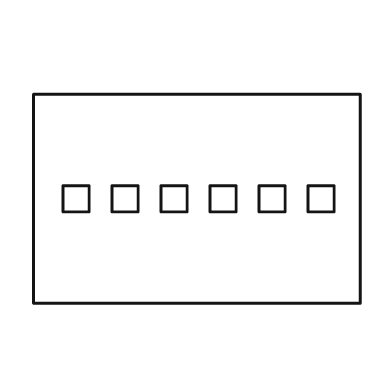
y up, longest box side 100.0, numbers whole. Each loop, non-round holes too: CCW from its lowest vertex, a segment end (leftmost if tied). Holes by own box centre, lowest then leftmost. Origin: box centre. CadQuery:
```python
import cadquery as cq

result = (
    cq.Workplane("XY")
    .moveTo(-50.0, -32.0)
    .lineTo(50.0, -32.0)
    .lineTo(50.0, 32.0)
    .lineTo(-50.0, 32.0)
    .close()
    .moveTo(-41.0, -4.0)
    .lineTo(-33.0, -4.0)
    .lineTo(-33.0, 4.0)
    .lineTo(-41.0, 4.0)
    .close()
    .moveTo(-26.0, -4.0)
    .lineTo(-18.0, -4.0)
    .lineTo(-18.0, 4.0)
    .lineTo(-26.0, 4.0)
    .close()
    .moveTo(-11.0, -4.0)
    .lineTo(-3.0, -4.0)
    .lineTo(-3.0, 4.0)
    .lineTo(-11.0, 4.0)
    .close()
    .moveTo(4.0, -4.0)
    .lineTo(12.0, -4.0)
    .lineTo(12.0, 4.0)
    .lineTo(4.0, 4.0)
    .close()
    .moveTo(19.0, -4.0)
    .lineTo(27.0, -4.0)
    .lineTo(27.0, 4.0)
    .lineTo(19.0, 4.0)
    .close()
    .moveTo(34.0, -4.0)
    .lineTo(42.0, -4.0)
    .lineTo(42.0, 4.0)
    .lineTo(34.0, 4.0)
    .close()
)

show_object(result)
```